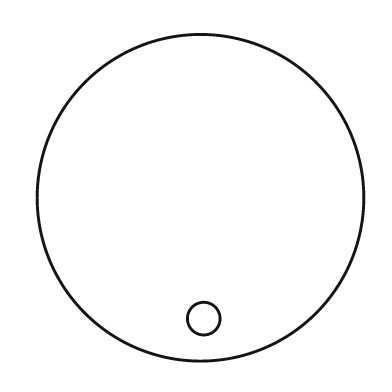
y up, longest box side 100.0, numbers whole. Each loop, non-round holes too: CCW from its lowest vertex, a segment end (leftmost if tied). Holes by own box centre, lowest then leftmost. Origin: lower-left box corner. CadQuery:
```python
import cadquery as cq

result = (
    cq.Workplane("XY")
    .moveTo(50.0, 50.0)
    .circle(50.0)
    .moveTo(51.0, 13.0)
    .circle(5.0)
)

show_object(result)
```